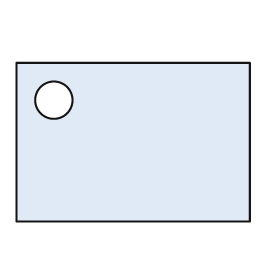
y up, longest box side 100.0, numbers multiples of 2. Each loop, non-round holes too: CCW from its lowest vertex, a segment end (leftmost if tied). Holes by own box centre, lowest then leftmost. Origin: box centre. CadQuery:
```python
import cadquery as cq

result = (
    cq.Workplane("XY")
    .moveTo(-50.0, -34.0)
    .lineTo(50.0, -34.0)
    .lineTo(50.0, 34.0)
    .lineTo(-50.0, 34.0)
    .close()
    .moveTo(-34.0, 18.0)
    .circle(8.0)
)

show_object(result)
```